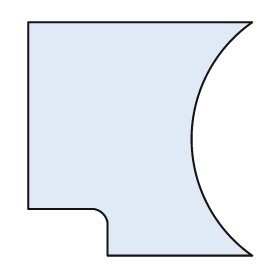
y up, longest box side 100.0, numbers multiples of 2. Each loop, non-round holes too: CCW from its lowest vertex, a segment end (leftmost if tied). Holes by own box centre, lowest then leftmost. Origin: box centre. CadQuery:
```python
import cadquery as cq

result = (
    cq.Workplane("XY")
    .moveTo(-14.0, -50.0)
    .lineTo(48.0, -50.0)
    .threePointArc((22.0, 0.0), (48.0, 50.0))
    .lineTo(-48.0, 50.0)
    .lineTo(-48.0, -30.0)
    .lineTo(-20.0, -30.0)
    .threePointArc((-16.0, -32.0), (-14.0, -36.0))
    .close()
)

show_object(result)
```